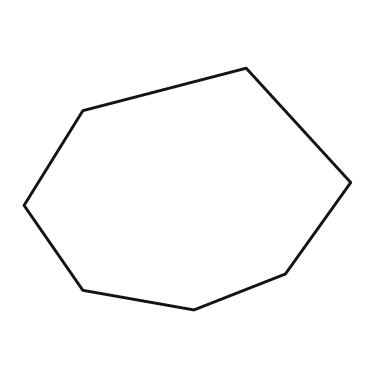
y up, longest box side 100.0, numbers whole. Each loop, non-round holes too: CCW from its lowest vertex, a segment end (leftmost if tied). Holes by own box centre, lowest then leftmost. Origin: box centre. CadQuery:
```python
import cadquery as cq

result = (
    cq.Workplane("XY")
    .moveTo(2.0, -37.0)
    .lineTo(30.0, -26.0)
    .lineTo(50.0, 2.0)
    .lineTo(18.0, 37.0)
    .lineTo(-32.0, 24.0)
    .lineTo(-50.0, -5.0)
    .lineTo(-32.0, -31.0)
    .close()
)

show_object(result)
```